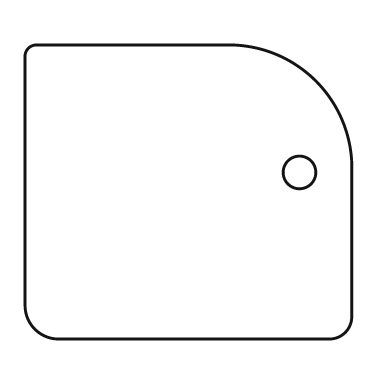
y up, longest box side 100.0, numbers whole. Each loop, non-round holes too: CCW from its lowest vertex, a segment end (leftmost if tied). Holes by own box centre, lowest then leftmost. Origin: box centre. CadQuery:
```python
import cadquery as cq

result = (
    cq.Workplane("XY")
    .moveTo(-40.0, -45.0)
    .lineTo(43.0, -45.0)
    .threePointArc((48.0, -43.0), (50.0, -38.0))
    .lineTo(50.0, 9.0)
    .threePointArc((39.0, 34.0), (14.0, 45.0))
    .lineTo(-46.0, 45.0)
    .threePointArc((-49.0, 44.0), (-50.0, 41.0))
    .lineTo(-50.0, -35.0)
    .threePointArc((-47.0, -42.0), (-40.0, -45.0))
    .close()
    .moveTo(34.0, 6.0)
    .circle(5.0)
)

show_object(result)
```